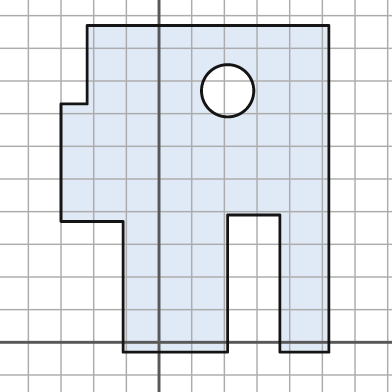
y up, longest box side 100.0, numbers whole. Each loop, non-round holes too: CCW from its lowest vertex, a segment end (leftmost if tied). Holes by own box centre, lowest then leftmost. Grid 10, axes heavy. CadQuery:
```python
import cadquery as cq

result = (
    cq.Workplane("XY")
    .moveTo(-11.0, -3.0)
    .lineTo(21.0, -3.0)
    .lineTo(21.0, 39.0)
    .lineTo(37.0, 39.0)
    .lineTo(37.0, -3.0)
    .lineTo(52.0, -3.0)
    .lineTo(52.0, 97.0)
    .lineTo(-22.0, 97.0)
    .lineTo(-22.0, 73.0)
    .lineTo(-30.0, 73.0)
    .lineTo(-30.0, 37.0)
    .lineTo(-11.0, 37.0)
    .close()
    .moveTo(21.0, 77.0)
    .circle(8.0)
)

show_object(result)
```